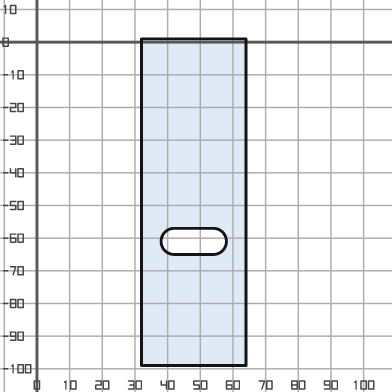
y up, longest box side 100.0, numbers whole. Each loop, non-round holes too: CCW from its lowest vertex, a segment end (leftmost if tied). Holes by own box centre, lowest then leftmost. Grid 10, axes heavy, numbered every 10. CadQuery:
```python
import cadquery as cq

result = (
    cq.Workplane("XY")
    .moveTo(32.0, -99.0)
    .lineTo(64.0, -99.0)
    .lineTo(64.0, 1.0)
    .lineTo(32.0, 1.0)
    .close()
    .moveTo(42.0, -65.0)
    .lineTo(54.0, -65.0)
    .threePointArc((58.0, -61.0), (54.0, -57.0))
    .lineTo(42.0, -57.0)
    .threePointArc((38.0, -61.0), (42.0, -65.0))
    .close()
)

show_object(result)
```